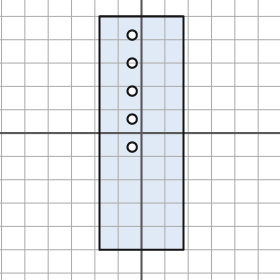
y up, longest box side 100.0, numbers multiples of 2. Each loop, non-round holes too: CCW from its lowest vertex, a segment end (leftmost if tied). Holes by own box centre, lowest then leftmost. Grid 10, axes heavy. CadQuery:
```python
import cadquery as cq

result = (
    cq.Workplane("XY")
    .moveTo(-18.0, -50.0)
    .lineTo(18.0, -50.0)
    .lineTo(18.0, 50.0)
    .lineTo(-18.0, 50.0)
    .close()
    .moveTo(-4.0, -6.0)
    .circle(2.0)
    .moveTo(-4.0, 6.0)
    .circle(2.0)
    .moveTo(-4.0, 18.0)
    .circle(2.0)
    .moveTo(-4.0, 30.0)
    .circle(2.0)
    .moveTo(-4.0, 42.0)
    .circle(2.0)
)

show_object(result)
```